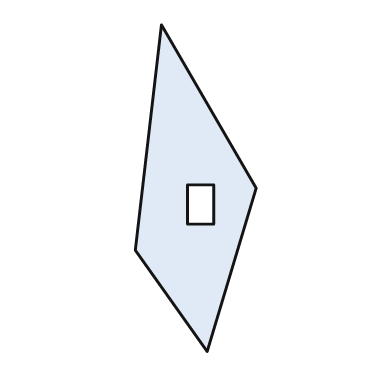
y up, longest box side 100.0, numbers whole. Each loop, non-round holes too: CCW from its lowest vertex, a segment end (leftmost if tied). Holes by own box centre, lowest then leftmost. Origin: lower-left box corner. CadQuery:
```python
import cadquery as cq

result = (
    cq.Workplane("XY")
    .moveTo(22.0, 0.0)
    .lineTo(37.0, 50.0)
    .lineTo(8.0, 100.0)
    .lineTo(0.0, 31.0)
    .close()
    .moveTo(16.0, 39.0)
    .lineTo(24.0, 39.0)
    .lineTo(24.0, 51.0)
    .lineTo(16.0, 51.0)
    .close()
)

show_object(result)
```